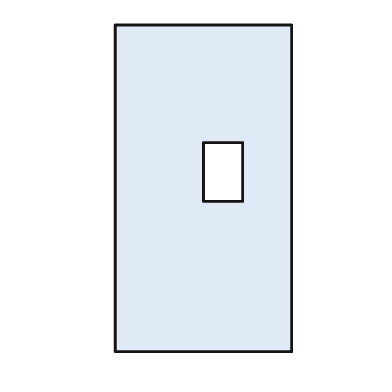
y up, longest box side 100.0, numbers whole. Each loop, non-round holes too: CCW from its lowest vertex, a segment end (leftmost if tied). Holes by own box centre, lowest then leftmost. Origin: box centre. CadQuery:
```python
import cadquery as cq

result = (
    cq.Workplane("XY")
    .moveTo(-27.0, -50.0)
    .lineTo(27.0, -50.0)
    .lineTo(27.0, 50.0)
    .lineTo(-27.0, 50.0)
    .close()
    .moveTo(0.0, -4.0)
    .lineTo(12.0, -4.0)
    .lineTo(12.0, 14.0)
    .lineTo(0.0, 14.0)
    .close()
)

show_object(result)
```